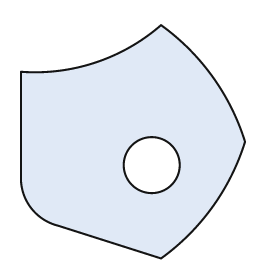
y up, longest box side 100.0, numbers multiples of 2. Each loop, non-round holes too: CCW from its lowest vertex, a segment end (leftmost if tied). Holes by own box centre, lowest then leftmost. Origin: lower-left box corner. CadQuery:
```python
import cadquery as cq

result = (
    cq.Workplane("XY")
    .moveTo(60.0, 0.0)
    .threePointArc((82.0, 22.0), (96.0, 50.0))
    .threePointArc((82.0, 78.0), (60.0, 100.0))
    .threePointArc((32.0, 84.0), (0.0, 80.0))
    .lineTo(0.0, 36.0)
    .threePointArc((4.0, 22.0), (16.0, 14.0))
    .close()
    .moveTo(56.0, 40.0)
    .circle(12.0)
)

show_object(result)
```